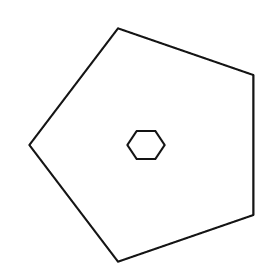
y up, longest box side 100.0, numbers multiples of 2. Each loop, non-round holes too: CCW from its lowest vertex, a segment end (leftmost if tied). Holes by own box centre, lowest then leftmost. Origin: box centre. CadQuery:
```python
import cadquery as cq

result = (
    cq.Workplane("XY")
    .moveTo(-10.0, -50.0)
    .lineTo(48.0, -30.0)
    .lineTo(48.0, 30.0)
    .lineTo(-10.0, 50.0)
    .lineTo(-48.0, 0.0)
    .close()
    .moveTo(-2.0, -6.0)
    .lineTo(6.0, -6.0)
    .lineTo(10.0, 0.0)
    .lineTo(6.0, 6.0)
    .lineTo(-2.0, 6.0)
    .lineTo(-6.0, 0.0)
    .close()
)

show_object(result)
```